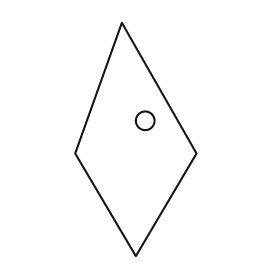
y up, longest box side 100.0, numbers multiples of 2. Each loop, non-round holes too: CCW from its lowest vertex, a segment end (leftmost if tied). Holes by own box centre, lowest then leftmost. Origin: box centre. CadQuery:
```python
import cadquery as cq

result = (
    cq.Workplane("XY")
    .moveTo(0.0, -50.0)
    .lineTo(26.0, -6.0)
    .lineTo(-6.0, 50.0)
    .lineTo(-26.0, -6.0)
    .close()
    .moveTo(4.0, 8.0)
    .circle(4.0)
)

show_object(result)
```